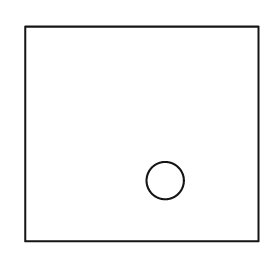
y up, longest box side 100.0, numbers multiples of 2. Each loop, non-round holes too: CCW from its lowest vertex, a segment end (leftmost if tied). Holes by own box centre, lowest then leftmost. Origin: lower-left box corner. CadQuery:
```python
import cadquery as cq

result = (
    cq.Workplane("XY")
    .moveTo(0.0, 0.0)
    .lineTo(100.0, 0.0)
    .lineTo(100.0, 92.0)
    .lineTo(0.0, 92.0)
    .close()
    .moveTo(60.0, 26.0)
    .circle(8.0)
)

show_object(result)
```